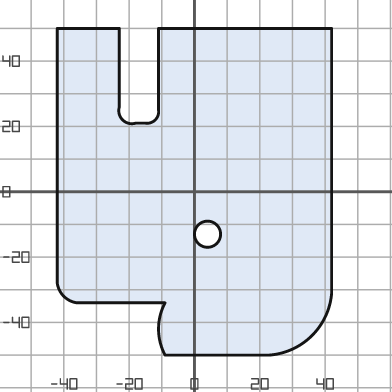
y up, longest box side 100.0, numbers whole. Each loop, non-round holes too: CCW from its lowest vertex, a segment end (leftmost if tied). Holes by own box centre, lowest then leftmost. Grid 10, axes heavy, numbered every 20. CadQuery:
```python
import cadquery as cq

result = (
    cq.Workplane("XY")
    .moveTo(-9.0, -50.0)
    .lineTo(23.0, -50.0)
    .threePointArc((36.0, -44.0), (42.0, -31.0))
    .lineTo(42.0, 50.0)
    .lineTo(-11.0, 50.0)
    .lineTo(-11.0, 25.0)
    .threePointArc((-12.0, 22.0), (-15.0, 21.0))
    .lineTo(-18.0, 21.0)
    .threePointArc((-22.0, 22.0), (-23.0, 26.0))
    .lineTo(-23.0, 50.0)
    .lineTo(-42.0, 50.0)
    .lineTo(-42.0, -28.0)
    .threePointArc((-40.0, -32.0), (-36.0, -34.0))
    .lineTo(-9.0, -34.0)
    .threePointArc((-11.0, -42.0), (-9.0, -50.0))
    .close()
    .moveTo(4.0, -13.0)
    .circle(4.0)
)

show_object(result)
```